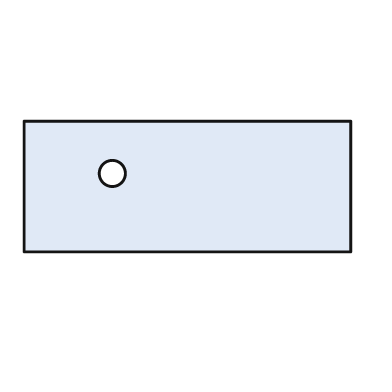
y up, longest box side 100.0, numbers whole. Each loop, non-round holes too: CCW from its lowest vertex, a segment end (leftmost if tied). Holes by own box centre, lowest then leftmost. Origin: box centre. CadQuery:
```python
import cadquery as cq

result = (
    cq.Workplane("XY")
    .moveTo(-50.0, -20.0)
    .lineTo(50.0, -20.0)
    .lineTo(50.0, 20.0)
    .lineTo(-50.0, 20.0)
    .close()
    .moveTo(-23.0, 4.0)
    .circle(4.0)
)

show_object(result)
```